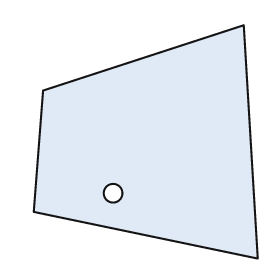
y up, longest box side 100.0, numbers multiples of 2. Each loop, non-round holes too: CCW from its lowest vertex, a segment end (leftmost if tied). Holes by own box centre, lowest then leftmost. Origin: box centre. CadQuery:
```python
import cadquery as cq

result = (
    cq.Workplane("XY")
    .moveTo(48.0, -50.0)
    .lineTo(42.0, 50.0)
    .lineTo(-44.0, 22.0)
    .lineTo(-48.0, -30.0)
    .close()
    .moveTo(-14.0, -22.0)
    .circle(4.0)
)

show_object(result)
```